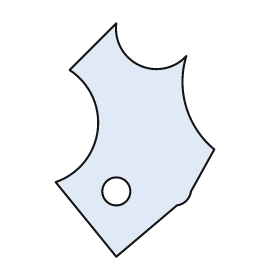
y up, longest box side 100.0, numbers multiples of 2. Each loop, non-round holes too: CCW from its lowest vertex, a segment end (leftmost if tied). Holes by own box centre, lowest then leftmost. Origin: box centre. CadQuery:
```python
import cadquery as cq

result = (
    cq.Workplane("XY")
    .moveTo(-8.0, -50.0)
    .lineTo(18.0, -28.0)
    .threePointArc((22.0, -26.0), (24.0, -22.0))
    .lineTo(34.0, -4.0)
    .threePointArc((22.0, 14.0), (22.0, 36.0))
    .threePointArc((2.0, 32.0), (-8.0, 50.0))
    .lineTo(-28.0, 30.0)
    .threePointArc((-16.0, 4.0), (-34.0, -18.0))
    .close()
    .moveTo(-8.0, -22.0)
    .circle(6.0)
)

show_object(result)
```